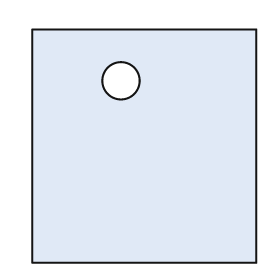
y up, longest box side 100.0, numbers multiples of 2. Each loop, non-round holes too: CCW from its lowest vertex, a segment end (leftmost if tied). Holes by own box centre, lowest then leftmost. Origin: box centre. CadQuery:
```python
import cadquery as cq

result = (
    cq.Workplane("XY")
    .moveTo(-48.0, -50.0)
    .lineTo(48.0, -50.0)
    .lineTo(48.0, 50.0)
    .lineTo(-48.0, 50.0)
    .close()
    .moveTo(-10.0, 28.0)
    .circle(8.0)
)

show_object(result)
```